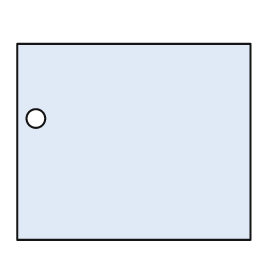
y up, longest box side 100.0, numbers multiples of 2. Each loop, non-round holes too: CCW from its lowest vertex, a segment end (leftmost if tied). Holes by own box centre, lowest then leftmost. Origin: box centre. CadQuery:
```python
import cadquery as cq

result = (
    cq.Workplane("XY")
    .moveTo(-50.0, -42.0)
    .lineTo(50.0, -42.0)
    .lineTo(50.0, 42.0)
    .lineTo(-50.0, 42.0)
    .close()
    .moveTo(-42.0, 10.0)
    .circle(4.0)
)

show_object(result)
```